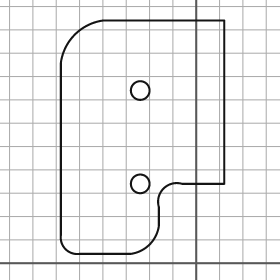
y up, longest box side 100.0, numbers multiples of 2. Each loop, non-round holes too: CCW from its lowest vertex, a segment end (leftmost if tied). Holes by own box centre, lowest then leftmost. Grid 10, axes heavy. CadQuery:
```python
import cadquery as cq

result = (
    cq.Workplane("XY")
    .moveTo(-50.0, 4.0)
    .lineTo(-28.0, 4.0)
    .threePointArc((-20.0, 8.0), (-16.0, 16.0))
    .lineTo(-16.0, 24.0)
    .threePointArc((-14.0, 32.0), (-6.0, 34.0))
    .lineTo(12.0, 34.0)
    .lineTo(12.0, 104.0)
    .lineTo(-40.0, 104.0)
    .threePointArc((-52.0, 98.0), (-58.0, 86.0))
    .lineTo(-58.0, 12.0)
    .threePointArc((-56.0, 6.0), (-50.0, 4.0))
    .close()
    .moveTo(-24.0, 34.0)
    .circle(4.0)
    .moveTo(-24.0, 74.0)
    .circle(4.0)
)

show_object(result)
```